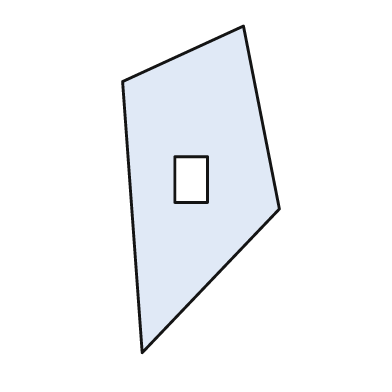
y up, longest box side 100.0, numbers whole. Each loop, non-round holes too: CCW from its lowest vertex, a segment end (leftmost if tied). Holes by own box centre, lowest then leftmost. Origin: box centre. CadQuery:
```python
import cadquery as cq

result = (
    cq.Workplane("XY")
    .moveTo(-18.0, -50.0)
    .lineTo(24.0, -6.0)
    .lineTo(13.0, 50.0)
    .lineTo(-24.0, 33.0)
    .close()
    .moveTo(-8.0, -4.0)
    .lineTo(2.0, -4.0)
    .lineTo(2.0, 10.0)
    .lineTo(-8.0, 10.0)
    .close()
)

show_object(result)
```